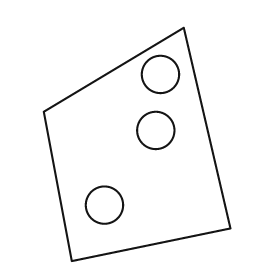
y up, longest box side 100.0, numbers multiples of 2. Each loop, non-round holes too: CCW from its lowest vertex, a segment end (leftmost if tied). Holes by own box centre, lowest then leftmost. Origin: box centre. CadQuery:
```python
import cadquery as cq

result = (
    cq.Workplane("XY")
    .moveTo(-28.0, -50.0)
    .lineTo(40.0, -36.0)
    .lineTo(20.0, 50.0)
    .lineTo(-40.0, 14.0)
    .close()
    .moveTo(-14.0, -26.0)
    .circle(8.0)
    .moveTo(8.0, 6.0)
    .circle(8.0)
    .moveTo(10.0, 30.0)
    .circle(8.0)
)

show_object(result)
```